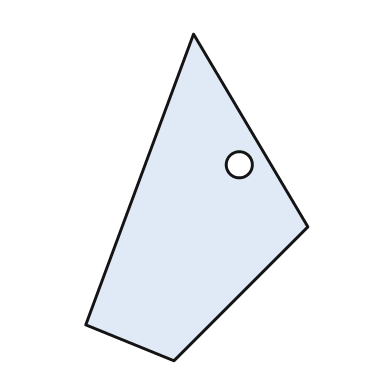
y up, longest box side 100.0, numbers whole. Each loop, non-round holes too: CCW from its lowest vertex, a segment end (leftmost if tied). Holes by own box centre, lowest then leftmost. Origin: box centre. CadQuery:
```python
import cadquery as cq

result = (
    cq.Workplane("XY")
    .moveTo(-7.0, -50.0)
    .lineTo(34.0, -9.0)
    .lineTo(-1.0, 50.0)
    .lineTo(-34.0, -39.0)
    .close()
    .moveTo(13.0, 10.0)
    .circle(4.0)
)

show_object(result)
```